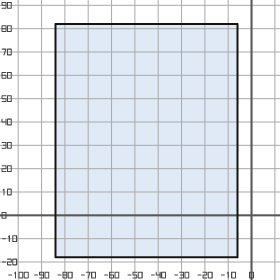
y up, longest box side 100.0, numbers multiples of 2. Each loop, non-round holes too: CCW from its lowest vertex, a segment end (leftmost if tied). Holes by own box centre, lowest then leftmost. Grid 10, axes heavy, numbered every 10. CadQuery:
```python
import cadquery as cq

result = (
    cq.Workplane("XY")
    .moveTo(-84.0, -18.0)
    .lineTo(-6.0, -18.0)
    .lineTo(-6.0, 82.0)
    .lineTo(-84.0, 82.0)
    .close()
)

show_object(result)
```